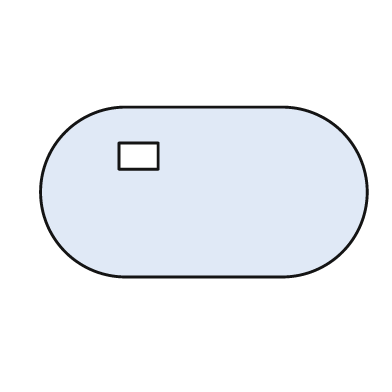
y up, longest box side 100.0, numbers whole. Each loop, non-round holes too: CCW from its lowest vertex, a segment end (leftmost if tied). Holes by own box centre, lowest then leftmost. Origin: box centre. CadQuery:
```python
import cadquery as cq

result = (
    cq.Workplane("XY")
    .moveTo(-24.0, -26.0)
    .lineTo(24.0, -26.0)
    .threePointArc((50.0, 0.0), (24.0, 26.0))
    .lineTo(-24.0, 26.0)
    .threePointArc((-50.0, 0.0), (-24.0, -26.0))
    .close()
    .moveTo(-26.0, 7.0)
    .lineTo(-14.0, 7.0)
    .lineTo(-14.0, 15.0)
    .lineTo(-26.0, 15.0)
    .close()
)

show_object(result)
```